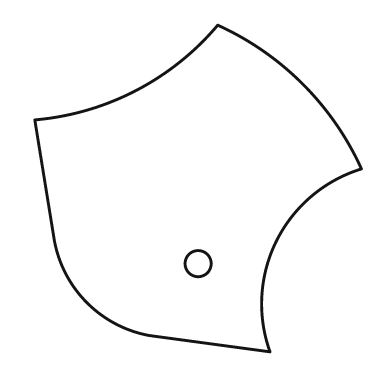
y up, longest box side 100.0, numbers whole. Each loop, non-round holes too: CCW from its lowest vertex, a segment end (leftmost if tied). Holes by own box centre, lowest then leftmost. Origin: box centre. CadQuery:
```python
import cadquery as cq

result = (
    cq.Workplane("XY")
    .moveTo(22.0, -50.0)
    .threePointArc((24.0, -16.0), (50.0, 6.0))
    .threePointArc((32.0, 32.0), (6.0, 50.0))
    .threePointArc((-19.0, 30.0), (-50.0, 21.0))
    .lineTo(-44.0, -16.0)
    .threePointArc((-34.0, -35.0), (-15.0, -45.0))
    .close()
    .moveTo(0.0, -23.0)
    .circle(4.0)
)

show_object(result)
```